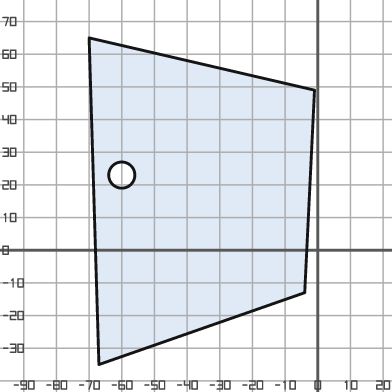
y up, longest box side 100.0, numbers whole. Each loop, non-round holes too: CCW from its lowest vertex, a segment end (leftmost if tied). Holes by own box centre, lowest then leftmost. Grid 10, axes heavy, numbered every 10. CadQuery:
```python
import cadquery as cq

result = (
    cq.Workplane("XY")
    .moveTo(-67.0, -35.0)
    .lineTo(-4.0, -13.0)
    .lineTo(-1.0, 49.0)
    .lineTo(-70.0, 65.0)
    .close()
    .moveTo(-60.0, 23.0)
    .circle(4.0)
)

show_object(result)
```